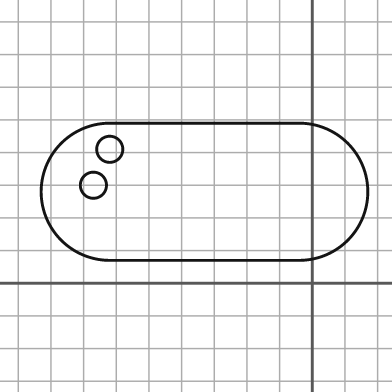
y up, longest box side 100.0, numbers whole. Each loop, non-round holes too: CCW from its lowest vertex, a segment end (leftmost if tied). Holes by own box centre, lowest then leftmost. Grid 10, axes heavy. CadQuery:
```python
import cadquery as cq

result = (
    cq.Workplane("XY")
    .moveTo(-62.0, 7.0)
    .lineTo(-4.0, 7.0)
    .threePointArc((17.0, 28.0), (-4.0, 49.0))
    .lineTo(-62.0, 49.0)
    .threePointArc((-83.0, 28.0), (-62.0, 7.0))
    .close()
    .moveTo(-67.0, 30.0)
    .circle(4.0)
    .moveTo(-62.0, 41.0)
    .circle(4.0)
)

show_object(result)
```